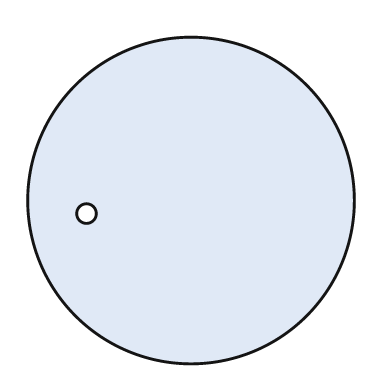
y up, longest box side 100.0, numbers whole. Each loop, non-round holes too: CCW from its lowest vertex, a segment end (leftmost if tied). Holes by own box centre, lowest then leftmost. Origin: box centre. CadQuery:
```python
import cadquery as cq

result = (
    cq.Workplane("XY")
    .moveTo(0.0, 0.0)
    .circle(50.0)
    .moveTo(-32.0, -4.0)
    .circle(3.0)
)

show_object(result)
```